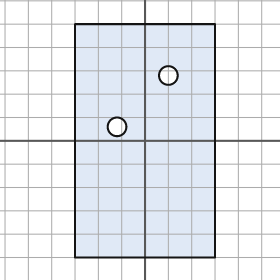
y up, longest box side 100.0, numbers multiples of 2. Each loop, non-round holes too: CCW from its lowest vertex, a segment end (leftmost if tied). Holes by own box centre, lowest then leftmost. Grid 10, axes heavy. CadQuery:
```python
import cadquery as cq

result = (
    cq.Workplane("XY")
    .moveTo(-30.0, -50.0)
    .lineTo(30.0, -50.0)
    .lineTo(30.0, 50.0)
    .lineTo(-30.0, 50.0)
    .close()
    .moveTo(-12.0, 6.0)
    .circle(4.0)
    .moveTo(10.0, 28.0)
    .circle(4.0)
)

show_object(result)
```